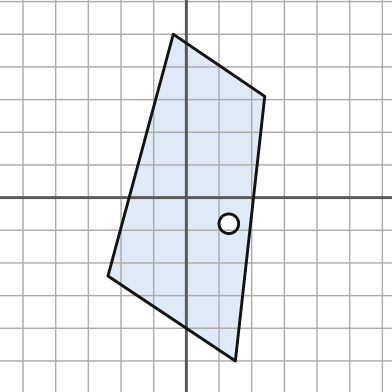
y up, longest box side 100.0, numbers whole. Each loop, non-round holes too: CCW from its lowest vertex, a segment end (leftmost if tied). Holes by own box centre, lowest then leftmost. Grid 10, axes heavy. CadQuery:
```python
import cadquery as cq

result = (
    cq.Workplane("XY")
    .moveTo(15.0, -50.0)
    .lineTo(24.0, 31.0)
    .lineTo(-4.0, 50.0)
    .lineTo(-24.0, -24.0)
    .close()
    .moveTo(13.0, -8.0)
    .circle(3.0)
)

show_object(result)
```